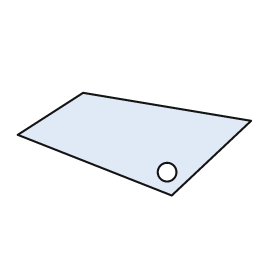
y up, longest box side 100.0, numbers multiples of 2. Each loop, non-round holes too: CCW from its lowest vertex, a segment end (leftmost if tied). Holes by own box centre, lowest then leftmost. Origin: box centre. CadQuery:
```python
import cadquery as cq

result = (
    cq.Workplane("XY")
    .moveTo(16.0, -22.0)
    .lineTo(50.0, 10.0)
    .lineTo(-22.0, 22.0)
    .lineTo(-50.0, 4.0)
    .close()
    .moveTo(14.0, -12.0)
    .circle(4.0)
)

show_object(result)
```